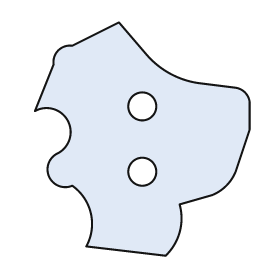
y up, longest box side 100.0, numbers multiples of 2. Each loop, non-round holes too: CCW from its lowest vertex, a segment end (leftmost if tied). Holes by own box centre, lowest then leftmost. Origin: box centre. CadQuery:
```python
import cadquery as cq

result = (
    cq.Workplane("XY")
    .moveTo(10.0, -50.0)
    .threePointArc((16.0, -40.0), (16.0, -28.0))
    .lineTo(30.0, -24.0)
    .threePointArc((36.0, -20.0), (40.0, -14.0))
    .lineTo(46.0, 4.0)
    .lineTo(46.0, 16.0)
    .threePointArc((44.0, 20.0), (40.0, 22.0))
    .lineTo(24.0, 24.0)
    .threePointArc((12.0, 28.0), (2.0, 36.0))
    .lineTo(-10.0, 50.0)
    .lineTo(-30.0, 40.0)
    .threePointArc((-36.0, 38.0), (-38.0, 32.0))
    .lineTo(-46.0, 12.0)
    .threePointArc((-32.0, 8.0), (-36.0, -6.0))
    .threePointArc((-40.0, -16.0), (-30.0, -20.0))
    .threePointArc((-22.0, -32.0), (-24.0, -46.0))
    .close()
    .moveTo(0.0, -14.0)
    .circle(6.0)
    .moveTo(0.0, 14.0)
    .circle(6.0)
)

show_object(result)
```